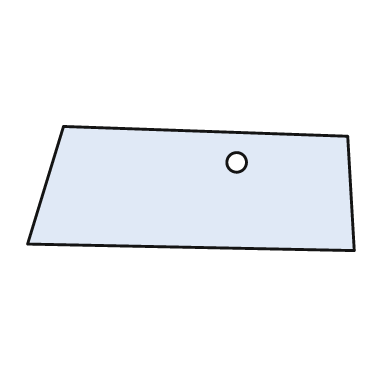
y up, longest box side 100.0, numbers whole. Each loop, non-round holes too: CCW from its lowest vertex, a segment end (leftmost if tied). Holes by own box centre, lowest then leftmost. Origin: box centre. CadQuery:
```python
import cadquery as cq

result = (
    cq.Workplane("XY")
    .moveTo(50.0, -19.0)
    .lineTo(48.0, 16.0)
    .lineTo(-39.0, 19.0)
    .lineTo(-50.0, -17.0)
    .close()
    .moveTo(14.0, 8.0)
    .circle(3.0)
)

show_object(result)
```